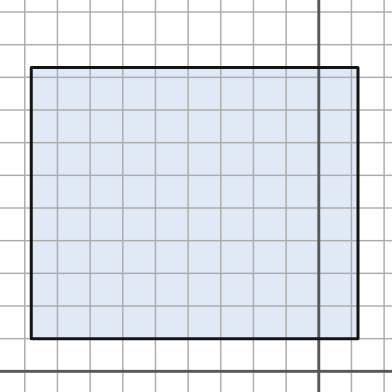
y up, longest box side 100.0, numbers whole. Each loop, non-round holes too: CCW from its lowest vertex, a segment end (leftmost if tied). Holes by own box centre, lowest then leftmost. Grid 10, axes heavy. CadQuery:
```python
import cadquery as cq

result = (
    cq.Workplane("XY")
    .moveTo(-88.0, 10.0)
    .lineTo(12.0, 10.0)
    .lineTo(12.0, 93.0)
    .lineTo(-88.0, 93.0)
    .close()
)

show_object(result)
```